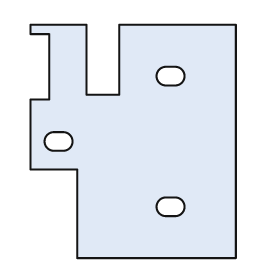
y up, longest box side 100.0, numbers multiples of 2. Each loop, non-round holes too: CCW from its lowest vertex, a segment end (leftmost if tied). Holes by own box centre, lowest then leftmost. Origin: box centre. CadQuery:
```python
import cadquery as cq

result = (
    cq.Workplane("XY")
    .moveTo(-24.0, -50.0)
    .lineTo(44.0, -50.0)
    .lineTo(44.0, 50.0)
    .lineTo(-6.0, 50.0)
    .lineTo(-6.0, 20.0)
    .lineTo(-20.0, 20.0)
    .lineTo(-20.0, 50.0)
    .lineTo(-44.0, 50.0)
    .lineTo(-44.0, 46.0)
    .lineTo(-36.0, 46.0)
    .lineTo(-36.0, 18.0)
    .lineTo(-44.0, 18.0)
    .lineTo(-44.0, -12.0)
    .lineTo(-24.0, -12.0)
    .close()
    .moveTo(14.0, -32.0)
    .lineTo(18.0, -32.0)
    .threePointArc((22.0, -28.0), (18.0, -24.0))
    .lineTo(14.0, -24.0)
    .threePointArc((10.0, -28.0), (14.0, -32.0))
    .close()
    .moveTo(-34.0, -4.0)
    .lineTo(-30.0, -4.0)
    .threePointArc((-26.0, 0.0), (-30.0, 4.0))
    .lineTo(-34.0, 4.0)
    .threePointArc((-38.0, 0.0), (-34.0, -4.0))
    .close()
    .moveTo(14.0, 24.0)
    .lineTo(18.0, 24.0)
    .threePointArc((22.0, 28.0), (18.0, 32.0))
    .lineTo(14.0, 32.0)
    .threePointArc((10.0, 28.0), (14.0, 24.0))
    .close()
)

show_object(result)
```